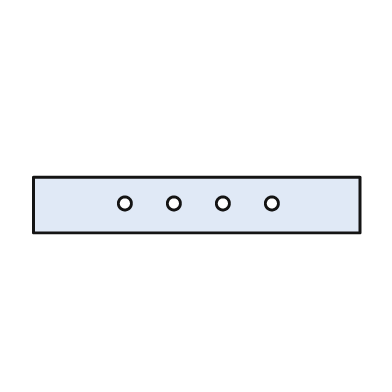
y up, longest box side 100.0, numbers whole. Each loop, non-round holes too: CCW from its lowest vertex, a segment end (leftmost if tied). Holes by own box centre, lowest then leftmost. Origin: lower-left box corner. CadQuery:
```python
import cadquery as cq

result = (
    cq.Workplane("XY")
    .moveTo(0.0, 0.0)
    .lineTo(100.0, 0.0)
    .lineTo(100.0, 17.0)
    .lineTo(0.0, 17.0)
    .close()
    .moveTo(28.0, 9.0)
    .circle(2.0)
    .moveTo(43.0, 9.0)
    .circle(2.0)
    .moveTo(58.0, 9.0)
    .circle(2.0)
    .moveTo(73.0, 9.0)
    .circle(2.0)
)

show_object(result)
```